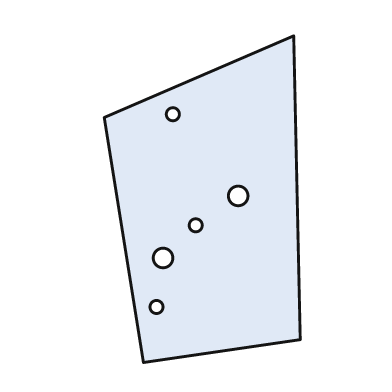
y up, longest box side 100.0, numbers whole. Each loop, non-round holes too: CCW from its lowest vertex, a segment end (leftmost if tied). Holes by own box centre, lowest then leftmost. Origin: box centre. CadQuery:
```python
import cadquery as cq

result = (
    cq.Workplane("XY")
    .moveTo(-18.0, -50.0)
    .lineTo(30.0, -43.0)
    .lineTo(28.0, 50.0)
    .lineTo(-30.0, 25.0)
    .close()
    .moveTo(-14.0, -33.0)
    .circle(2.0)
    .moveTo(-12.0, -18.0)
    .circle(3.0)
    .moveTo(-2.0, -8.0)
    .circle(2.0)
    .moveTo(11.0, 1.0)
    .circle(3.0)
    .moveTo(-9.0, 26.0)
    .circle(2.0)
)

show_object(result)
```